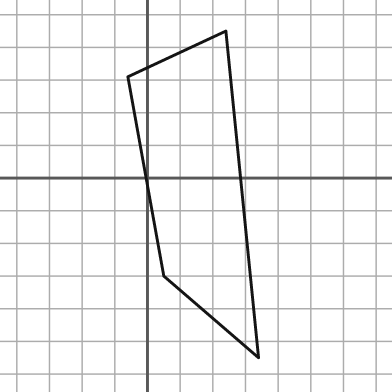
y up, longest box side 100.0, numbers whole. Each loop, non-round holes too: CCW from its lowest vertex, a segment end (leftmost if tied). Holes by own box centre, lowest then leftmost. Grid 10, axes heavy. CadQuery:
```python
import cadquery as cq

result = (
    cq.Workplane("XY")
    .moveTo(34.0, -55.0)
    .lineTo(24.0, 45.0)
    .lineTo(-6.0, 31.0)
    .lineTo(5.0, -30.0)
    .close()
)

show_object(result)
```